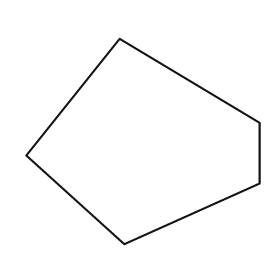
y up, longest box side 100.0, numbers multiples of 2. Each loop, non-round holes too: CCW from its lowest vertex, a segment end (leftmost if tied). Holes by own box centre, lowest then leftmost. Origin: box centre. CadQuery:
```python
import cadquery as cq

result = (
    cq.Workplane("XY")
    .moveTo(-8.0, -44.0)
    .lineTo(50.0, -18.0)
    .lineTo(50.0, 8.0)
    .lineTo(-10.0, 44.0)
    .lineTo(-50.0, -6.0)
    .close()
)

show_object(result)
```